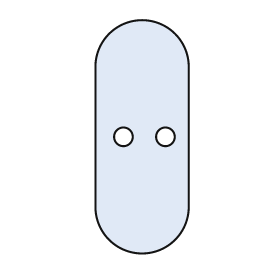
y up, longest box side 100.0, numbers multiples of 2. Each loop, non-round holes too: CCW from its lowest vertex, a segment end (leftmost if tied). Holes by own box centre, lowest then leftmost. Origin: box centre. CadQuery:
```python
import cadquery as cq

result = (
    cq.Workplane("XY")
    .moveTo(-20.0, -30.0)
    .threePointArc((0.0, -50.0), (20.0, -30.0))
    .lineTo(20.0, 30.0)
    .threePointArc((0.0, 50.0), (-20.0, 30.0))
    .close()
    .moveTo(-8.0, 0.0)
    .circle(4.0)
    .moveTo(10.0, 0.0)
    .circle(4.0)
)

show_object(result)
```